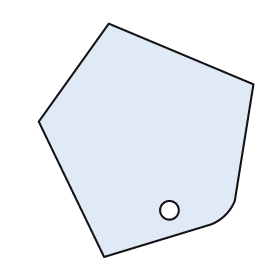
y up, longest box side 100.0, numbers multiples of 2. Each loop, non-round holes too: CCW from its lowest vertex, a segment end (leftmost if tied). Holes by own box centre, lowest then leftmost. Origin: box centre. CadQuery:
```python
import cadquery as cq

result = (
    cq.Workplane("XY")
    .moveTo(-18.0, -50.0)
    .lineTo(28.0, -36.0)
    .threePointArc((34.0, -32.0), (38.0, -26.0))
    .lineTo(46.0, 24.0)
    .lineTo(-16.0, 50.0)
    .lineTo(-46.0, 8.0)
    .close()
    .moveTo(10.0, -30.0)
    .circle(4.0)
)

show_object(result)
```